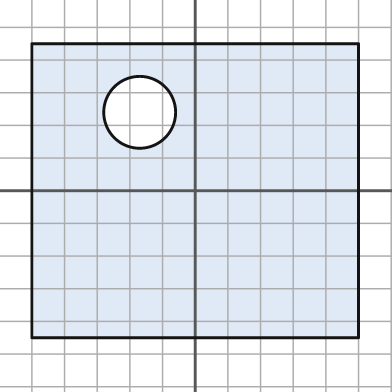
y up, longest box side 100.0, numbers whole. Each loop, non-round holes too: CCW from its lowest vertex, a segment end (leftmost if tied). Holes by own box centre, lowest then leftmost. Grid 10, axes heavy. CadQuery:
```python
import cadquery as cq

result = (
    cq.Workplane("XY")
    .moveTo(-50.0, -45.0)
    .lineTo(50.0, -45.0)
    .lineTo(50.0, 45.0)
    .lineTo(-50.0, 45.0)
    .close()
    .moveTo(-17.0, 24.0)
    .circle(11.0)
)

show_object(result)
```